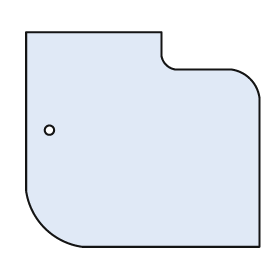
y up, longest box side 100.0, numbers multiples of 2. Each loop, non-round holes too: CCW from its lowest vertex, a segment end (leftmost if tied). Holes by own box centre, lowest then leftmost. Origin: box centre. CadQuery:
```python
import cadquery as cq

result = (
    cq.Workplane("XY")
    .moveTo(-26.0, -46.0)
    .lineTo(50.0, -46.0)
    .lineTo(50.0, 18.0)
    .threePointArc((46.0, 26.0), (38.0, 30.0))
    .lineTo(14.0, 30.0)
    .threePointArc((10.0, 32.0), (8.0, 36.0))
    .lineTo(8.0, 46.0)
    .lineTo(-50.0, 46.0)
    .lineTo(-50.0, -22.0)
    .threePointArc((-42.0, -38.0), (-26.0, -46.0))
    .close()
    .moveTo(-40.0, 4.0)
    .circle(2.0)
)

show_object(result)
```